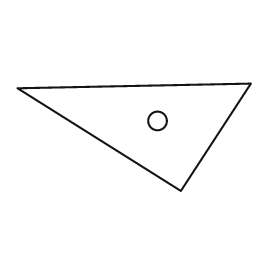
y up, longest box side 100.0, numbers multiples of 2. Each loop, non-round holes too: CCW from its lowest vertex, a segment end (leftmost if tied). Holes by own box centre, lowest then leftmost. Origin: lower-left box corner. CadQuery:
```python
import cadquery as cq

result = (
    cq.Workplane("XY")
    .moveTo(70.0, 0.0)
    .lineTo(100.0, 46.0)
    .lineTo(0.0, 44.0)
    .close()
    .moveTo(60.0, 30.0)
    .circle(4.0)
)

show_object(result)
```